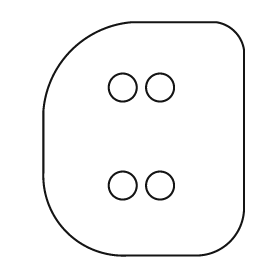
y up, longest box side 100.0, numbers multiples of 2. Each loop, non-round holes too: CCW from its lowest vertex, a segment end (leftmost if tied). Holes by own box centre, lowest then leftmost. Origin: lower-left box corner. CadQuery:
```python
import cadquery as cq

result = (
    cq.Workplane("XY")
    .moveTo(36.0, 0.0)
    .lineTo(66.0, 0.0)
    .threePointArc((80.0, 6.0), (86.0, 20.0))
    .lineTo(86.0, 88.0)
    .threePointArc((82.0, 96.0), (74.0, 100.0))
    .lineTo(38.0, 100.0)
    .threePointArc((12.0, 88.0), (0.0, 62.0))
    .lineTo(0.0, 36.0)
    .threePointArc((10.0, 10.0), (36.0, 0.0))
    .close()
    .moveTo(34.0, 30.0)
    .circle(6.0)
    .moveTo(50.0, 30.0)
    .circle(6.0)
    .moveTo(34.0, 72.0)
    .circle(6.0)
    .moveTo(50.0, 72.0)
    .circle(6.0)
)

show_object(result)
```